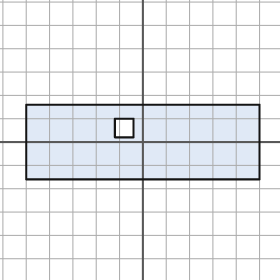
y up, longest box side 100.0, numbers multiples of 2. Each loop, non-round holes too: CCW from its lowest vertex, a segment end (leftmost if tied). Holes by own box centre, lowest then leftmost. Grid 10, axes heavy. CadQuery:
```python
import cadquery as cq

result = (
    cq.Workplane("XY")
    .moveTo(-50.0, -16.0)
    .lineTo(50.0, -16.0)
    .lineTo(50.0, 16.0)
    .lineTo(-50.0, 16.0)
    .close()
    .moveTo(-12.0, 2.0)
    .lineTo(-4.0, 2.0)
    .lineTo(-4.0, 10.0)
    .lineTo(-12.0, 10.0)
    .close()
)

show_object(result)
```